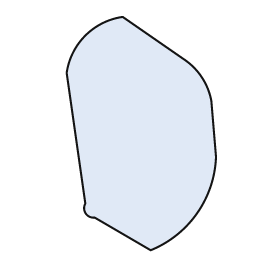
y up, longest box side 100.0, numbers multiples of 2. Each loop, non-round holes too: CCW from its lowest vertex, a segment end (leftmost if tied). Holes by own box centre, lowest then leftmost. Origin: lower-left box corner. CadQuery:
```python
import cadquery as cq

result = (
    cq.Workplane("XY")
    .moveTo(36.0, 0.0)
    .threePointArc((56.0, 16.0), (64.0, 40.0))
    .lineTo(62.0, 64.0)
    .threePointArc((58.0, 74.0), (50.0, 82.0))
    .lineTo(24.0, 100.0)
    .threePointArc((8.0, 92.0), (0.0, 76.0))
    .lineTo(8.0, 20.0)
    .threePointArc((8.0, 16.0), (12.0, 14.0))
    .close()
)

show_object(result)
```